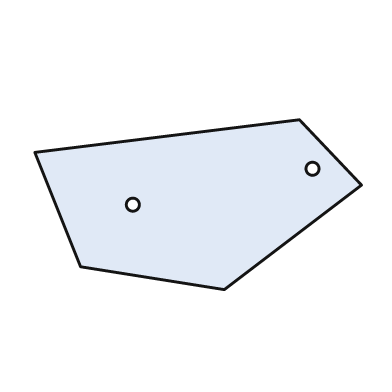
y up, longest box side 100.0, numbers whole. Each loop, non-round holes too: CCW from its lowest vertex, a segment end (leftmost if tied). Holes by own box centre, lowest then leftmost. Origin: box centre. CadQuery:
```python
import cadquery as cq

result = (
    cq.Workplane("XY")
    .moveTo(8.0, -26.0)
    .lineTo(50.0, 6.0)
    .lineTo(31.0, 26.0)
    .lineTo(-50.0, 16.0)
    .lineTo(-36.0, -19.0)
    .close()
    .moveTo(-20.0, 0.0)
    .circle(2.0)
    .moveTo(35.0, 11.0)
    .circle(2.0)
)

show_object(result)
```